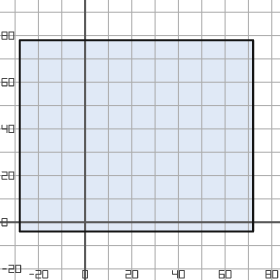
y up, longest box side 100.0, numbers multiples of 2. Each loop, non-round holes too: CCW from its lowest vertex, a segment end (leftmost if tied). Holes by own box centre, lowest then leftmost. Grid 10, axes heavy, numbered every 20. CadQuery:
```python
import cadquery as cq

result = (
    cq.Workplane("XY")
    .moveTo(-28.0, -4.0)
    .lineTo(72.0, -4.0)
    .lineTo(72.0, 78.0)
    .lineTo(-28.0, 78.0)
    .close()
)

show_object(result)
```